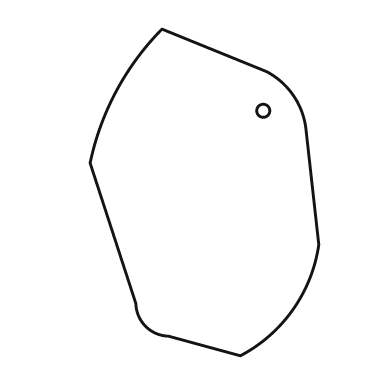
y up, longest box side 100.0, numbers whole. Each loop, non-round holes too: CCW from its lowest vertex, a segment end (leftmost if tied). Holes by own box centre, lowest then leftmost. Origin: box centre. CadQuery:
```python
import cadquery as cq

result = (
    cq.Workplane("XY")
    .moveTo(11.0, -50.0)
    .threePointArc((27.0, -36.0), (35.0, -16.0))
    .lineTo(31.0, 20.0)
    .threePointArc((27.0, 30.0), (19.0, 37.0))
    .lineTo(-13.0, 50.0)
    .threePointArc((-27.0, 31.0), (-35.0, 9.0))
    .lineTo(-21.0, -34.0)
    .threePointArc((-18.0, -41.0), (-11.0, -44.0))
    .close()
    .moveTo(18.0, 25.0)
    .circle(2.0)
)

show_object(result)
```